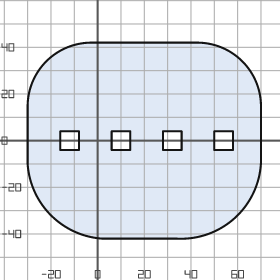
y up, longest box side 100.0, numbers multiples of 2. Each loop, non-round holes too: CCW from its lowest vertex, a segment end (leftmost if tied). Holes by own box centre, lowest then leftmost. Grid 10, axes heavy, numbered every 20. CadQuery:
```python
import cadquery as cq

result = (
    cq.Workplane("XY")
    .moveTo(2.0, -42.0)
    .lineTo(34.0, -42.0)
    .threePointArc((60.0, -32.0), (70.0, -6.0))
    .lineTo(70.0, 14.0)
    .threePointArc((62.0, 34.0), (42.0, 42.0))
    .lineTo(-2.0, 42.0)
    .threePointArc((-22.0, 34.0), (-30.0, 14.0))
    .lineTo(-30.0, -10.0)
    .threePointArc((-20.0, -32.0), (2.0, -42.0))
    .close()
    .moveTo(-16.0, -4.0)
    .lineTo(-8.0, -4.0)
    .lineTo(-8.0, 4.0)
    .lineTo(-16.0, 4.0)
    .close()
    .moveTo(6.0, -4.0)
    .lineTo(14.0, -4.0)
    .lineTo(14.0, 4.0)
    .lineTo(6.0, 4.0)
    .close()
    .moveTo(28.0, -4.0)
    .lineTo(36.0, -4.0)
    .lineTo(36.0, 4.0)
    .lineTo(28.0, 4.0)
    .close()
    .moveTo(50.0, -4.0)
    .lineTo(58.0, -4.0)
    .lineTo(58.0, 4.0)
    .lineTo(50.0, 4.0)
    .close()
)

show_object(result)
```